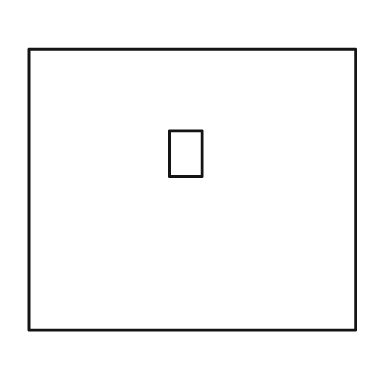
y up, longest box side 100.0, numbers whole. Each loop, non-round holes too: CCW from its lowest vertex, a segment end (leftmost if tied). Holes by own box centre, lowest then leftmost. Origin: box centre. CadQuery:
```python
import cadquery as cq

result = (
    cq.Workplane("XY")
    .moveTo(-50.0, -43.0)
    .lineTo(50.0, -43.0)
    .lineTo(50.0, 43.0)
    .lineTo(-50.0, 43.0)
    .close()
    .moveTo(-7.0, 4.0)
    .lineTo(3.0, 4.0)
    .lineTo(3.0, 18.0)
    .lineTo(-7.0, 18.0)
    .close()
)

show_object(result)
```